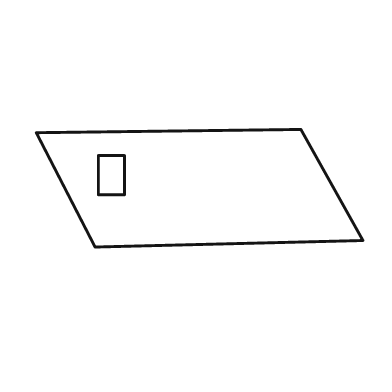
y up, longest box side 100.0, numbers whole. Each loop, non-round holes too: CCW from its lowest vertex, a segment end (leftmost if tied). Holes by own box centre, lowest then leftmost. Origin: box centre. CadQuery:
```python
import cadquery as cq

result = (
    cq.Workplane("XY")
    .moveTo(-32.0, -18.0)
    .lineTo(50.0, -16.0)
    .lineTo(31.0, 18.0)
    .lineTo(-50.0, 17.0)
    .close()
    .moveTo(-31.0, -2.0)
    .lineTo(-23.0, -2.0)
    .lineTo(-23.0, 10.0)
    .lineTo(-31.0, 10.0)
    .close()
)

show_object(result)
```